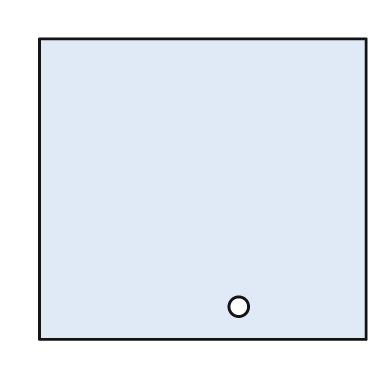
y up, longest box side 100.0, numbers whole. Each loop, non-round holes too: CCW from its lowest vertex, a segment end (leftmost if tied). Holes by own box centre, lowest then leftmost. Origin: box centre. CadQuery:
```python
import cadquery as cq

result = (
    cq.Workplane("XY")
    .moveTo(-50.0, -46.0)
    .lineTo(50.0, -46.0)
    .lineTo(50.0, 46.0)
    .lineTo(-50.0, 46.0)
    .close()
    .moveTo(11.0, -36.0)
    .circle(3.0)
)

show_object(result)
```